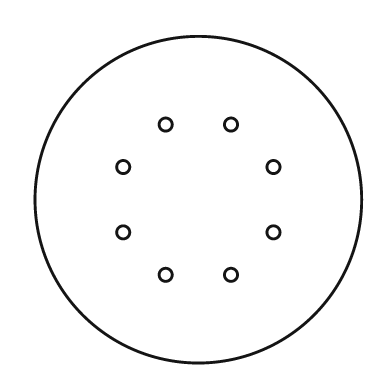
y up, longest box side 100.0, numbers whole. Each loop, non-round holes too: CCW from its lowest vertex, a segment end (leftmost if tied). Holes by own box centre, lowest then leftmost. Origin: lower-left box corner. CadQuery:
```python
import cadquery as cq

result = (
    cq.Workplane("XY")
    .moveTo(50.0, 50.0)
    .circle(50.0)
    .moveTo(40.0, 27.0)
    .circle(2.0)
    .moveTo(60.0, 27.0)
    .circle(2.0)
    .moveTo(27.0, 40.0)
    .circle(2.0)
    .moveTo(73.0, 40.0)
    .circle(2.0)
    .moveTo(27.0, 60.0)
    .circle(2.0)
    .moveTo(73.0, 60.0)
    .circle(2.0)
    .moveTo(40.0, 73.0)
    .circle(2.0)
    .moveTo(60.0, 73.0)
    .circle(2.0)
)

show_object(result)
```